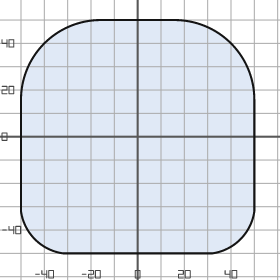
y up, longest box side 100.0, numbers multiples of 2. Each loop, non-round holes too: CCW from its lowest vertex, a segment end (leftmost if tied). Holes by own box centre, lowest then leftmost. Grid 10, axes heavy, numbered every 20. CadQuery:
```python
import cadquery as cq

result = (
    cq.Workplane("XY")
    .moveTo(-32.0, -50.0)
    .lineTo(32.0, -50.0)
    .threePointArc((44.0, -44.0), (50.0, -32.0))
    .lineTo(50.0, 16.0)
    .threePointArc((40.0, 40.0), (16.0, 50.0))
    .lineTo(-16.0, 50.0)
    .threePointArc((-40.0, 40.0), (-50.0, 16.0))
    .lineTo(-50.0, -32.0)
    .threePointArc((-44.0, -44.0), (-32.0, -50.0))
    .close()
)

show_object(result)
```